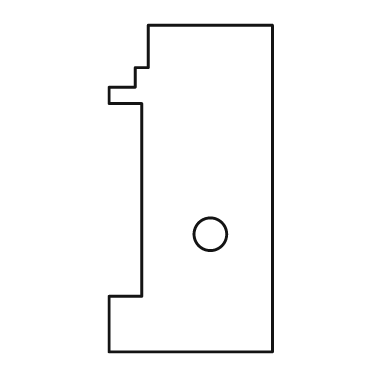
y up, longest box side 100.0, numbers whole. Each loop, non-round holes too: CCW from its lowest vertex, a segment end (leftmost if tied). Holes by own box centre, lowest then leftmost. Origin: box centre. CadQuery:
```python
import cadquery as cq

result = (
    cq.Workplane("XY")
    .moveTo(-25.0, -50.0)
    .lineTo(25.0, -50.0)
    .lineTo(25.0, 50.0)
    .lineTo(-13.0, 50.0)
    .lineTo(-13.0, 37.0)
    .lineTo(-17.0, 37.0)
    .lineTo(-17.0, 31.0)
    .lineTo(-25.0, 31.0)
    .lineTo(-25.0, 26.0)
    .lineTo(-15.0, 26.0)
    .lineTo(-15.0, -33.0)
    .lineTo(-25.0, -33.0)
    .close()
    .moveTo(6.0, -14.0)
    .circle(5.0)
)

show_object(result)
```